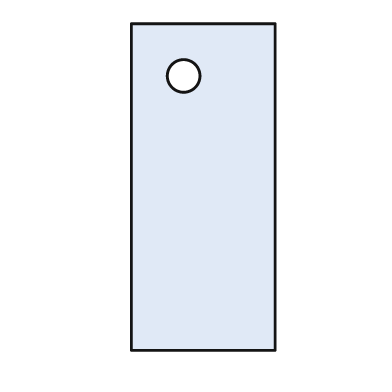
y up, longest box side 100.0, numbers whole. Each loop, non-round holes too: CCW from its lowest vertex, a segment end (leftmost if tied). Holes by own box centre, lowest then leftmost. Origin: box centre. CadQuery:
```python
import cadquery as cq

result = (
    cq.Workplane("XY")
    .moveTo(-22.0, -50.0)
    .lineTo(22.0, -50.0)
    .lineTo(22.0, 50.0)
    .lineTo(-22.0, 50.0)
    .close()
    .moveTo(-6.0, 34.0)
    .circle(5.0)
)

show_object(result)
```